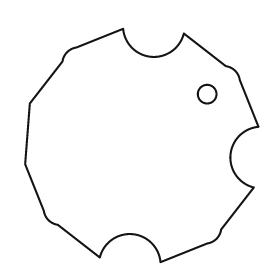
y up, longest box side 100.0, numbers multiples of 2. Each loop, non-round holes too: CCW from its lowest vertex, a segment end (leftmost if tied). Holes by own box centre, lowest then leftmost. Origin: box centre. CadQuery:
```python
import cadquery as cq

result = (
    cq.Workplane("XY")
    .moveTo(8.0, -50.0)
    .lineTo(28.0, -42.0)
    .threePointArc((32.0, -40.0), (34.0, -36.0))
    .lineTo(48.0, -18.0)
    .threePointArc((38.0, -4.0), (50.0, 8.0))
    .lineTo(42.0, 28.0)
    .threePointArc((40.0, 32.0), (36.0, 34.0))
    .lineTo(18.0, 48.0)
    .threePointArc((4.0, 38.0), (-8.0, 50.0))
    .lineTo(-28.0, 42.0)
    .threePointArc((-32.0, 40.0), (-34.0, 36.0))
    .lineTo(-48.0, 18.0)
    .lineTo(-50.0, -8.0)
    .lineTo(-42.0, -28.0)
    .threePointArc((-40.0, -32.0), (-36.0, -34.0))
    .lineTo(-18.0, -48.0)
    .threePointArc((-4.0, -38.0), (8.0, -50.0))
    .close()
    .moveTo(28.0, 22.0)
    .circle(4.0)
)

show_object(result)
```